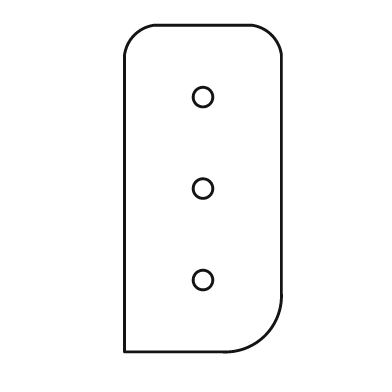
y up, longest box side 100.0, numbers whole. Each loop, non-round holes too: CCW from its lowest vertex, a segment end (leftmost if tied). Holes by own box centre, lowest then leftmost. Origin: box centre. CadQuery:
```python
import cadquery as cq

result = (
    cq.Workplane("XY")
    .moveTo(-24.0, -50.0)
    .lineTo(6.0, -50.0)
    .threePointArc((19.0, -45.0), (24.0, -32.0))
    .lineTo(24.0, 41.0)
    .threePointArc((21.0, 47.0), (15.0, 50.0))
    .lineTo(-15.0, 50.0)
    .threePointArc((-21.0, 47.0), (-24.0, 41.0))
    .close()
    .moveTo(0.0, -28.0)
    .circle(3.0)
    .moveTo(0.0, 0.0)
    .circle(3.0)
    .moveTo(0.0, 28.0)
    .circle(3.0)
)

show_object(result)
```